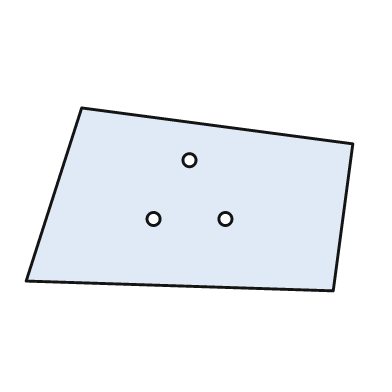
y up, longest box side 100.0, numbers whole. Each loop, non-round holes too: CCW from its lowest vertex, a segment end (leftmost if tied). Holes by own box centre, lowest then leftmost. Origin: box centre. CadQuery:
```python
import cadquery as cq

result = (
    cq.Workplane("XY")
    .moveTo(44.0, -28.0)
    .lineTo(50.0, 17.0)
    .lineTo(-33.0, 28.0)
    .lineTo(-50.0, -25.0)
    .close()
    .moveTo(-11.0, -6.0)
    .circle(2.0)
    .moveTo(11.0, -6.0)
    .circle(2.0)
    .moveTo(0.0, 12.0)
    .circle(2.0)
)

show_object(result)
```